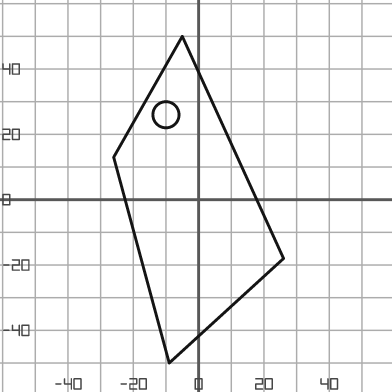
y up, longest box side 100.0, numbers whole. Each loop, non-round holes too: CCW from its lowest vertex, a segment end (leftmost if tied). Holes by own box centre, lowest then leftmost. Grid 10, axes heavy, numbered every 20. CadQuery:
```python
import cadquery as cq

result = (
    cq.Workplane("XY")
    .moveTo(-9.0, -50.0)
    .lineTo(26.0, -18.0)
    .lineTo(-5.0, 50.0)
    .lineTo(-26.0, 13.0)
    .close()
    .moveTo(-10.0, 26.0)
    .circle(4.0)
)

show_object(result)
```